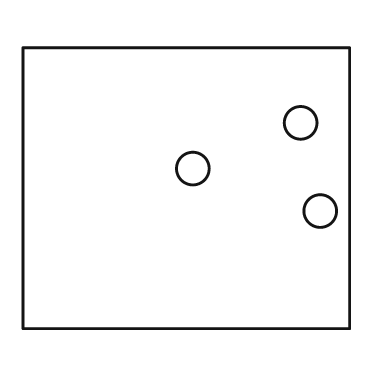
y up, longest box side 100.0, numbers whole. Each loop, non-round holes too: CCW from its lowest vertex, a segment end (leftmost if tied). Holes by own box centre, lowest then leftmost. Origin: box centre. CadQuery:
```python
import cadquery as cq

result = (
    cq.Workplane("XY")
    .moveTo(-50.0, -43.0)
    .lineTo(50.0, -43.0)
    .lineTo(50.0, 43.0)
    .lineTo(-50.0, 43.0)
    .close()
    .moveTo(41.0, -7.0)
    .circle(5.0)
    .moveTo(2.0, 6.0)
    .circle(5.0)
    .moveTo(35.0, 20.0)
    .circle(5.0)
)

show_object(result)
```